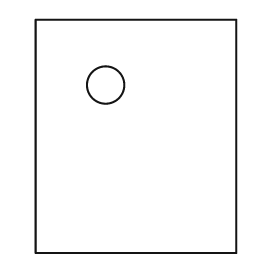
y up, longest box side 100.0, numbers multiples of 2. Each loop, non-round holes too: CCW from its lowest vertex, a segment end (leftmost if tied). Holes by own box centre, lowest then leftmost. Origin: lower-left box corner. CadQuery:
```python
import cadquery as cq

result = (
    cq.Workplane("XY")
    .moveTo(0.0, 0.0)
    .lineTo(86.0, 0.0)
    .lineTo(86.0, 100.0)
    .lineTo(0.0, 100.0)
    .close()
    .moveTo(30.0, 72.0)
    .circle(8.0)
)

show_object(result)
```